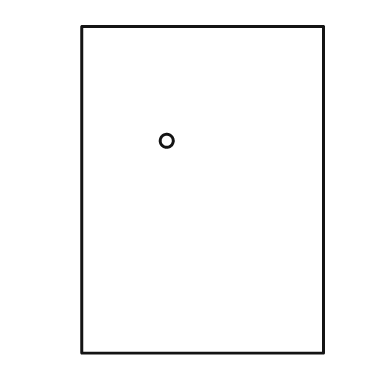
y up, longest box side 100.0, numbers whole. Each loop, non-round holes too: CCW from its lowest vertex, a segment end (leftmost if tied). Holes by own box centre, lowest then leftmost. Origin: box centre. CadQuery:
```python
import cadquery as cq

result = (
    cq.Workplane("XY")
    .moveTo(-37.0, -50.0)
    .lineTo(37.0, -50.0)
    .lineTo(37.0, 50.0)
    .lineTo(-37.0, 50.0)
    .close()
    .moveTo(-11.0, 15.0)
    .circle(2.0)
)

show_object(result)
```